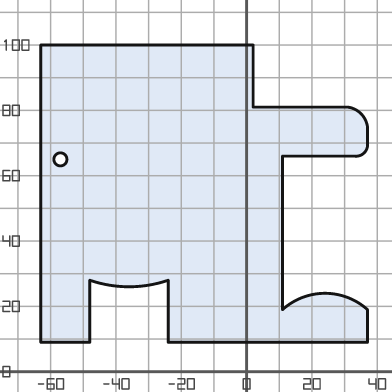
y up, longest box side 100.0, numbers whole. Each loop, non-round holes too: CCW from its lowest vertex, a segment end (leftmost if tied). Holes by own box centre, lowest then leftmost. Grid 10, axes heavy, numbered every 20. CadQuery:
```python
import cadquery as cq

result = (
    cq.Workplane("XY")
    .moveTo(-63.0, 9.0)
    .lineTo(-48.0, 9.0)
    .lineTo(-48.0, 28.0)
    .threePointArc((-36.0, 26.0), (-24.0, 28.0))
    .lineTo(-24.0, 9.0)
    .lineTo(37.0, 9.0)
    .lineTo(37.0, 19.0)
    .threePointArc((24.0, 24.0), (11.0, 19.0))
    .lineTo(11.0, 66.0)
    .lineTo(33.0, 66.0)
    .threePointArc((36.0, 67.0), (37.0, 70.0))
    .lineTo(37.0, 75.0)
    .threePointArc((35.0, 79.0), (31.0, 81.0))
    .lineTo(2.0, 81.0)
    .lineTo(2.0, 100.0)
    .lineTo(-63.0, 100.0)
    .close()
    .moveTo(-57.0, 65.0)
    .circle(2.0)
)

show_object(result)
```